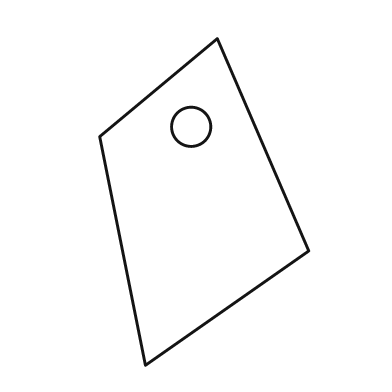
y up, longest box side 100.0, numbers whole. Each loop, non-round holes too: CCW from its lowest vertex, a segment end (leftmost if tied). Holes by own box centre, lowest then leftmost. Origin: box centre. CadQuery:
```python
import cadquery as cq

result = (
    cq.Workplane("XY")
    .moveTo(-18.0, -50.0)
    .lineTo(32.0, -15.0)
    .lineTo(4.0, 50.0)
    .lineTo(-32.0, 20.0)
    .close()
    .moveTo(-4.0, 23.0)
    .circle(6.0)
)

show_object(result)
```